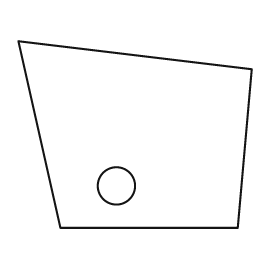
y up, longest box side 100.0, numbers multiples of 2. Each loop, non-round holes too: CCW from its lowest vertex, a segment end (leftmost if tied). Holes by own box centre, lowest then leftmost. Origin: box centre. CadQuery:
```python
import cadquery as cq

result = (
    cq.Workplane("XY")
    .moveTo(-32.0, -40.0)
    .lineTo(44.0, -40.0)
    .lineTo(50.0, 28.0)
    .lineTo(-50.0, 40.0)
    .close()
    .moveTo(-8.0, -22.0)
    .circle(8.0)
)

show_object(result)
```